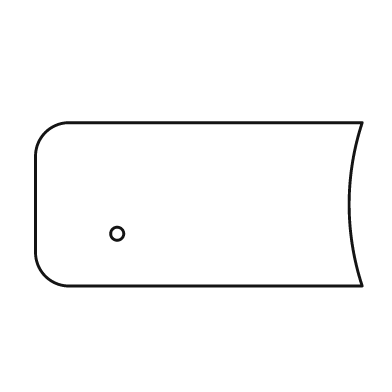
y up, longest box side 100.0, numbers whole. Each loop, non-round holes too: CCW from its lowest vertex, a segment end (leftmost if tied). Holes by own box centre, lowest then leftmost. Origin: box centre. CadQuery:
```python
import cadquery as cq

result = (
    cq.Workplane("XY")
    .moveTo(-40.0, -25.0)
    .lineTo(50.0, -25.0)
    .threePointArc((46.0, 0.0), (50.0, 25.0))
    .lineTo(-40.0, 25.0)
    .threePointArc((-47.0, 22.0), (-50.0, 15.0))
    .lineTo(-50.0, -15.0)
    .threePointArc((-47.0, -22.0), (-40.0, -25.0))
    .close()
    .moveTo(-25.0, -9.0)
    .circle(2.0)
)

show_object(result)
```